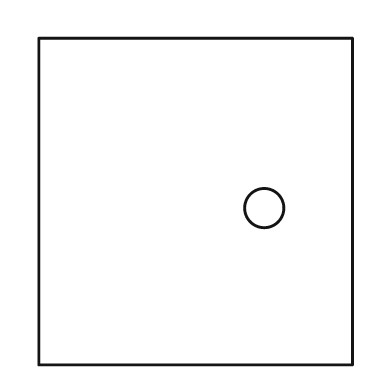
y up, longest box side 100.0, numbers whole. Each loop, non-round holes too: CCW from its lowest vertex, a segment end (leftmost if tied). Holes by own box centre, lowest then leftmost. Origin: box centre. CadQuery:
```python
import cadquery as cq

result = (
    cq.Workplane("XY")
    .moveTo(-48.0, -50.0)
    .lineTo(48.0, -50.0)
    .lineTo(48.0, 50.0)
    .lineTo(-48.0, 50.0)
    .close()
    .moveTo(21.0, -2.0)
    .circle(6.0)
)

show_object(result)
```